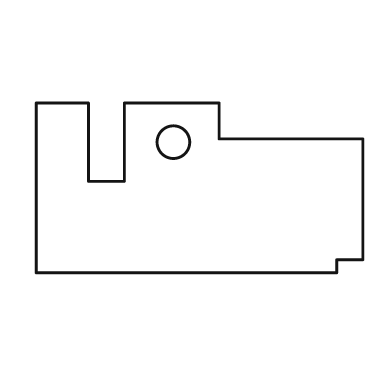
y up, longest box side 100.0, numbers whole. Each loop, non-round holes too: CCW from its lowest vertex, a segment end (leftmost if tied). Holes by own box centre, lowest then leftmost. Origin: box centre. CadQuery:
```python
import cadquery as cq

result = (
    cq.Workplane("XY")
    .moveTo(-50.0, -26.0)
    .lineTo(42.0, -26.0)
    .lineTo(42.0, -22.0)
    .lineTo(50.0, -22.0)
    .lineTo(50.0, 15.0)
    .lineTo(6.0, 15.0)
    .lineTo(6.0, 26.0)
    .lineTo(-23.0, 26.0)
    .lineTo(-23.0, 2.0)
    .lineTo(-34.0, 2.0)
    .lineTo(-34.0, 26.0)
    .lineTo(-50.0, 26.0)
    .close()
    .moveTo(-8.0, 14.0)
    .circle(5.0)
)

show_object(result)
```